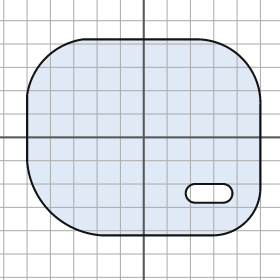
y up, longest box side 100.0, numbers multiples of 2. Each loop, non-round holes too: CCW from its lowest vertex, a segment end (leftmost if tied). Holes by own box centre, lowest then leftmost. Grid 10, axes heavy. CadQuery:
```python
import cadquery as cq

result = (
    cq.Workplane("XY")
    .moveTo(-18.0, -42.0)
    .lineTo(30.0, -42.0)
    .threePointArc((44.0, -36.0), (50.0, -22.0))
    .lineTo(50.0, 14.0)
    .threePointArc((42.0, 34.0), (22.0, 42.0))
    .lineTo(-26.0, 42.0)
    .threePointArc((-42.0, 34.0), (-50.0, 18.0))
    .lineTo(-50.0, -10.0)
    .threePointArc((-40.0, -32.0), (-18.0, -42.0))
    .close()
    .moveTo(22.0, -28.0)
    .lineTo(34.0, -28.0)
    .threePointArc((38.0, -24.0), (34.0, -20.0))
    .lineTo(22.0, -20.0)
    .threePointArc((18.0, -24.0), (22.0, -28.0))
    .close()
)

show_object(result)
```